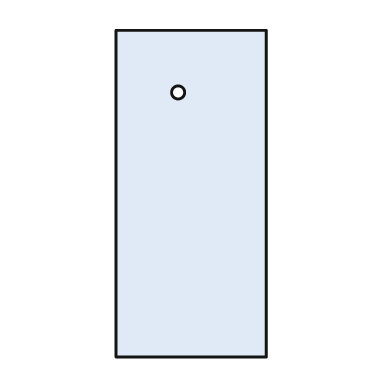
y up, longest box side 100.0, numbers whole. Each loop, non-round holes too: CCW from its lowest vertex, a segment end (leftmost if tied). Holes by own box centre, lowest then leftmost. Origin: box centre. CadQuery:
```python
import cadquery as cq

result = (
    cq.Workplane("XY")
    .moveTo(-23.0, -50.0)
    .lineTo(23.0, -50.0)
    .lineTo(23.0, 50.0)
    .lineTo(-23.0, 50.0)
    .close()
    .moveTo(-4.0, 31.0)
    .circle(2.0)
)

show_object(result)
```